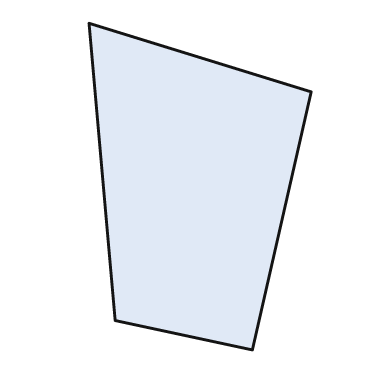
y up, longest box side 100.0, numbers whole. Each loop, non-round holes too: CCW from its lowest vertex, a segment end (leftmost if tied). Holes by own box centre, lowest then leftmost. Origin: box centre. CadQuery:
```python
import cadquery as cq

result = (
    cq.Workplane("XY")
    .moveTo(16.0, -50.0)
    .lineTo(34.0, 29.0)
    .lineTo(-34.0, 50.0)
    .lineTo(-26.0, -41.0)
    .close()
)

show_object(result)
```